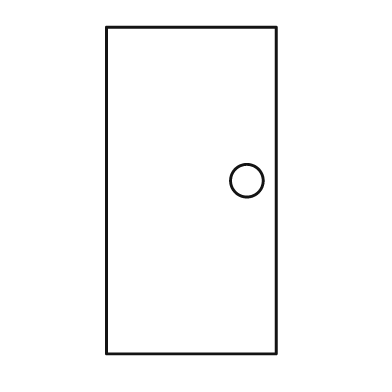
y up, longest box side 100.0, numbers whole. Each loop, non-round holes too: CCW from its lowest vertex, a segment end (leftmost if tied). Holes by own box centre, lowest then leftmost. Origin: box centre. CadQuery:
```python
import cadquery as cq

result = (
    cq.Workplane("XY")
    .moveTo(-26.0, -50.0)
    .lineTo(26.0, -50.0)
    .lineTo(26.0, 50.0)
    .lineTo(-26.0, 50.0)
    .close()
    .moveTo(17.0, 3.0)
    .circle(5.0)
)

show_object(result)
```